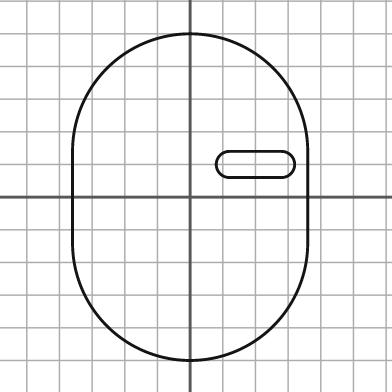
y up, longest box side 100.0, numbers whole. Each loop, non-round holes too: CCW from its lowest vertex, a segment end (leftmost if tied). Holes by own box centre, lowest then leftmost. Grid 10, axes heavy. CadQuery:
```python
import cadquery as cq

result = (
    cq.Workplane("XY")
    .moveTo(-36.0, -14.0)
    .threePointArc((0.0, -50.0), (36.0, -14.0))
    .lineTo(36.0, 14.0)
    .threePointArc((0.0, 50.0), (-36.0, 14.0))
    .close()
    .moveTo(12.0, 6.0)
    .lineTo(28.0, 6.0)
    .threePointArc((32.0, 10.0), (28.0, 14.0))
    .lineTo(12.0, 14.0)
    .threePointArc((8.0, 10.0), (12.0, 6.0))
    .close()
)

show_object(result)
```